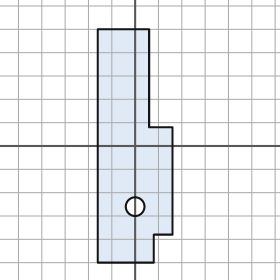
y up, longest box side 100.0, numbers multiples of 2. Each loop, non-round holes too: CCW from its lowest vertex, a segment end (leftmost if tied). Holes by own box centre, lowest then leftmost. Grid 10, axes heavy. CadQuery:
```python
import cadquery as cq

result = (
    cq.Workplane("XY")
    .moveTo(-16.0, -50.0)
    .lineTo(8.0, -50.0)
    .lineTo(8.0, -38.0)
    .lineTo(16.0, -38.0)
    .lineTo(16.0, 8.0)
    .lineTo(6.0, 8.0)
    .lineTo(6.0, 50.0)
    .lineTo(-16.0, 50.0)
    .close()
    .moveTo(0.0, -26.0)
    .circle(4.0)
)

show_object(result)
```